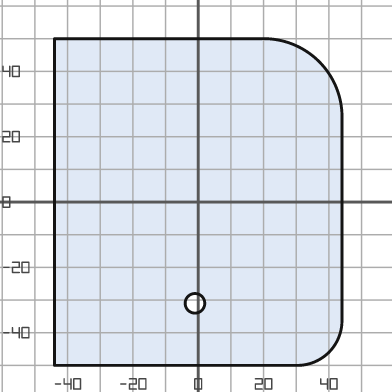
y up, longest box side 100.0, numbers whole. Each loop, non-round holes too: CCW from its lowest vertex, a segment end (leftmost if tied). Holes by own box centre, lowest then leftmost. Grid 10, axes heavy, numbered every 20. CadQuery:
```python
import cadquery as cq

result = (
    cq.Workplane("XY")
    .moveTo(-44.0, -50.0)
    .lineTo(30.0, -50.0)
    .threePointArc((40.0, -46.0), (44.0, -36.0))
    .lineTo(44.0, 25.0)
    .threePointArc((37.0, 43.0), (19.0, 50.0))
    .lineTo(-44.0, 50.0)
    .close()
    .moveTo(-1.0, -31.0)
    .circle(3.0)
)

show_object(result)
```